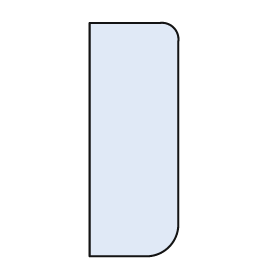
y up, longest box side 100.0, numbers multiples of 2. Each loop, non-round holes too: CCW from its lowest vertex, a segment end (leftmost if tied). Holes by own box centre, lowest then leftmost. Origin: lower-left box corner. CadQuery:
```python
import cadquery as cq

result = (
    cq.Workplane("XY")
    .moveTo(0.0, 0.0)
    .lineTo(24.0, 0.0)
    .threePointArc((34.0, 4.0), (38.0, 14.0))
    .lineTo(38.0, 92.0)
    .threePointArc((36.0, 98.0), (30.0, 100.0))
    .lineTo(0.0, 100.0)
    .close()
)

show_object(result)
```